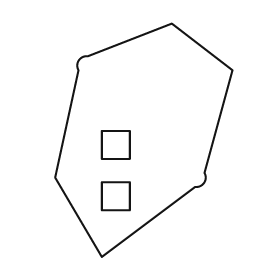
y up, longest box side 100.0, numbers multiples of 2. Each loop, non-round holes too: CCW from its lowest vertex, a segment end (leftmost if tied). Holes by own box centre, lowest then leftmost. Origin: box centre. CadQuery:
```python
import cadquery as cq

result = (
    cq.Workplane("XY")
    .moveTo(-18.0, -50.0)
    .lineTo(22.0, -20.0)
    .threePointArc((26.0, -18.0), (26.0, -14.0))
    .lineTo(38.0, 30.0)
    .lineTo(12.0, 50.0)
    .lineTo(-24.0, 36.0)
    .threePointArc((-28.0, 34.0), (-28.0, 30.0))
    .lineTo(-38.0, -16.0)
    .close()
    .moveTo(-18.0, -30.0)
    .lineTo(-6.0, -30.0)
    .lineTo(-6.0, -18.0)
    .lineTo(-18.0, -18.0)
    .close()
    .moveTo(-18.0, -8.0)
    .lineTo(-6.0, -8.0)
    .lineTo(-6.0, 4.0)
    .lineTo(-18.0, 4.0)
    .close()
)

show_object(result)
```